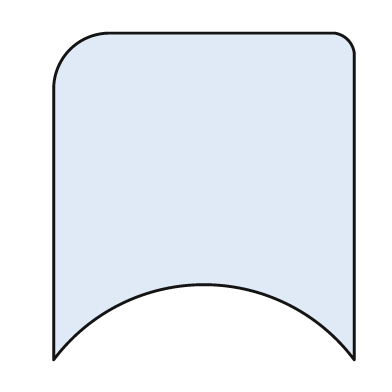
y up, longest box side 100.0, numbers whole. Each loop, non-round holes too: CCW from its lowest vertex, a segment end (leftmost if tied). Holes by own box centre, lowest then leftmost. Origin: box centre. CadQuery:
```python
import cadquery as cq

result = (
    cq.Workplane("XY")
    .moveTo(-46.0, -50.0)
    .threePointArc((0.0, -27.0), (46.0, -50.0))
    .lineTo(46.0, 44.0)
    .threePointArc((44.0, 48.0), (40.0, 50.0))
    .lineTo(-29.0, 50.0)
    .threePointArc((-41.0, 45.0), (-46.0, 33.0))
    .close()
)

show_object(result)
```